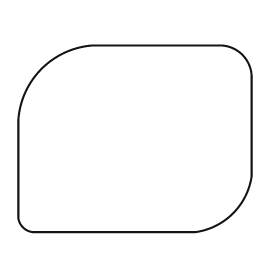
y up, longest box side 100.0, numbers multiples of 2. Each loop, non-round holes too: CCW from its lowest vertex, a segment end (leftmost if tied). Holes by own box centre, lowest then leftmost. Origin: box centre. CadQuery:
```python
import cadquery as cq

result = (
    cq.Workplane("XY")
    .moveTo(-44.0, -40.0)
    .lineTo(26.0, -40.0)
    .threePointArc((42.0, -32.0), (50.0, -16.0))
    .lineTo(50.0, 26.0)
    .threePointArc((46.0, 36.0), (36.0, 40.0))
    .lineTo(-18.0, 40.0)
    .threePointArc((-40.0, 30.0), (-50.0, 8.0))
    .lineTo(-50.0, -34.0)
    .threePointArc((-48.0, -38.0), (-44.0, -40.0))
    .close()
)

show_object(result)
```